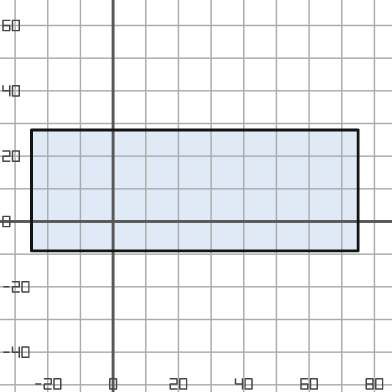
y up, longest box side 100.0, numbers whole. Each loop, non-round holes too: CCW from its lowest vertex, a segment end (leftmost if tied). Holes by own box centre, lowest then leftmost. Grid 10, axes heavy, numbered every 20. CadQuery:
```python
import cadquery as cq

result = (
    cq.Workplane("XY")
    .moveTo(-25.0, -9.0)
    .lineTo(75.0, -9.0)
    .lineTo(75.0, 28.0)
    .lineTo(-25.0, 28.0)
    .close()
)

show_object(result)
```